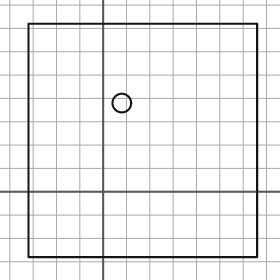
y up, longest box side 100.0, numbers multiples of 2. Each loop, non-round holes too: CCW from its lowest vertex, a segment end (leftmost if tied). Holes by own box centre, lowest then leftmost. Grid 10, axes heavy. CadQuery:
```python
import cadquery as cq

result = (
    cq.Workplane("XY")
    .moveTo(-32.0, -28.0)
    .lineTo(66.0, -28.0)
    .lineTo(66.0, 72.0)
    .lineTo(-32.0, 72.0)
    .close()
    .moveTo(8.0, 38.0)
    .circle(4.0)
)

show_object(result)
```